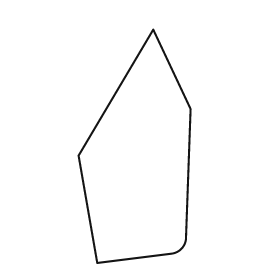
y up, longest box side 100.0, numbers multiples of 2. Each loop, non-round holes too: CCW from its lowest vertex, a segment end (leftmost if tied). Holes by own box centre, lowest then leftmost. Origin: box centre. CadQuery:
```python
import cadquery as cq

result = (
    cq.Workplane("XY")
    .moveTo(-16.0, -50.0)
    .lineTo(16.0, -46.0)
    .threePointArc((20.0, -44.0), (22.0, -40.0))
    .lineTo(24.0, 16.0)
    .lineTo(8.0, 50.0)
    .lineTo(-24.0, -4.0)
    .close()
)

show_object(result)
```